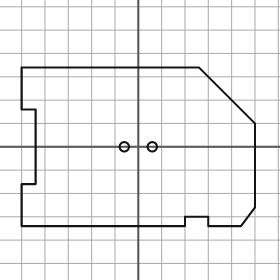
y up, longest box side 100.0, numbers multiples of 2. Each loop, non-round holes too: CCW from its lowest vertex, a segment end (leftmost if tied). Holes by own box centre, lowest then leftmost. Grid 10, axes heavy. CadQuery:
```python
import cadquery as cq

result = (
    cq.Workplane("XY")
    .moveTo(-50.0, -34.0)
    .lineTo(20.0, -34.0)
    .lineTo(20.0, -30.0)
    .lineTo(30.0, -30.0)
    .lineTo(30.0, -34.0)
    .lineTo(44.0, -34.0)
    .lineTo(50.0, -26.0)
    .lineTo(50.0, 10.0)
    .lineTo(26.0, 34.0)
    .lineTo(-50.0, 34.0)
    .lineTo(-50.0, 16.0)
    .lineTo(-44.0, 16.0)
    .lineTo(-44.0, -16.0)
    .lineTo(-50.0, -16.0)
    .close()
    .moveTo(-6.0, 0.0)
    .circle(2.0)
    .moveTo(6.0, 0.0)
    .circle(2.0)
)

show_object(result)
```